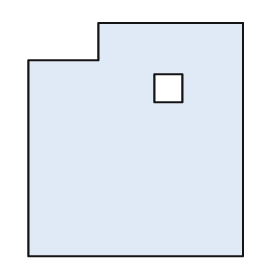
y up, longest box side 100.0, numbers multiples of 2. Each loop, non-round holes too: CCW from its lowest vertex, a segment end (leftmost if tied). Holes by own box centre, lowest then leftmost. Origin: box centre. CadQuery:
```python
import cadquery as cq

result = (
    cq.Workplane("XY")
    .moveTo(-46.0, -50.0)
    .lineTo(46.0, -50.0)
    .lineTo(46.0, 50.0)
    .lineTo(-16.0, 50.0)
    .lineTo(-16.0, 34.0)
    .lineTo(-46.0, 34.0)
    .close()
    .moveTo(8.0, 16.0)
    .lineTo(20.0, 16.0)
    .lineTo(20.0, 28.0)
    .lineTo(8.0, 28.0)
    .close()
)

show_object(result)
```